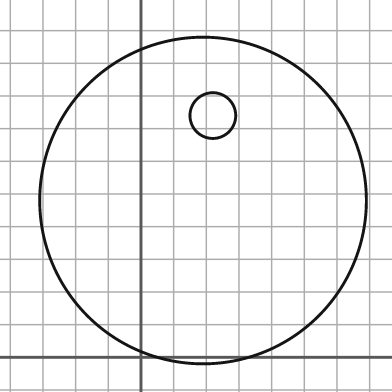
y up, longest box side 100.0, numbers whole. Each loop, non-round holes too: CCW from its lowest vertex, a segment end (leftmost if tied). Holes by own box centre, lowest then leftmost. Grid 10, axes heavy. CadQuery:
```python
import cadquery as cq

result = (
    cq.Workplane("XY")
    .moveTo(19.0, 48.0)
    .circle(50.0)
    .moveTo(22.0, 74.0)
    .circle(7.0)
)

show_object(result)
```